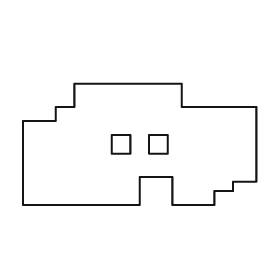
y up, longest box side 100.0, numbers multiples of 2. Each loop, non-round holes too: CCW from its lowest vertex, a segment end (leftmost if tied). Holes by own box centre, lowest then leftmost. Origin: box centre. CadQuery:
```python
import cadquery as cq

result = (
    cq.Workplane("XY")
    .moveTo(-50.0, -26.0)
    .lineTo(0.0, -26.0)
    .lineTo(0.0, -14.0)
    .lineTo(14.0, -14.0)
    .lineTo(14.0, -26.0)
    .lineTo(32.0, -26.0)
    .lineTo(32.0, -20.0)
    .lineTo(40.0, -20.0)
    .lineTo(40.0, -16.0)
    .lineTo(50.0, -16.0)
    .lineTo(50.0, 16.0)
    .lineTo(18.0, 16.0)
    .lineTo(18.0, 26.0)
    .lineTo(-28.0, 26.0)
    .lineTo(-28.0, 16.0)
    .lineTo(-36.0, 16.0)
    .lineTo(-36.0, 10.0)
    .lineTo(-50.0, 10.0)
    .close()
    .moveTo(-12.0, -4.0)
    .lineTo(-4.0, -4.0)
    .lineTo(-4.0, 4.0)
    .lineTo(-12.0, 4.0)
    .close()
    .moveTo(4.0, -4.0)
    .lineTo(12.0, -4.0)
    .lineTo(12.0, 4.0)
    .lineTo(4.0, 4.0)
    .close()
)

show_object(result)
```